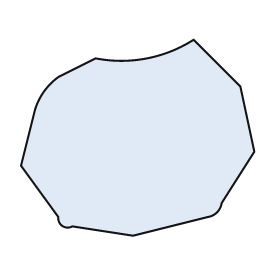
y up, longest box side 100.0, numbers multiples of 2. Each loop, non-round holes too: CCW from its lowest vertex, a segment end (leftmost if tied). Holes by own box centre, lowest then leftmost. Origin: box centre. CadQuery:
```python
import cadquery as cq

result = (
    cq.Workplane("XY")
    .moveTo(-2.0, -42.0)
    .lineTo(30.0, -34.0)
    .threePointArc((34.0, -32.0), (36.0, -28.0))
    .lineTo(50.0, -6.0)
    .lineTo(44.0, 22.0)
    .lineTo(24.0, 42.0)
    .threePointArc((4.0, 34.0), (-18.0, 34.0))
    .lineTo(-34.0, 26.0)
    .threePointArc((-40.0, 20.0), (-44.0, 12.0))
    .lineTo(-50.0, -12.0)
    .lineTo(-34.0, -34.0)
    .threePointArc((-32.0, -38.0), (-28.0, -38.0))
    .close()
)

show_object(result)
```